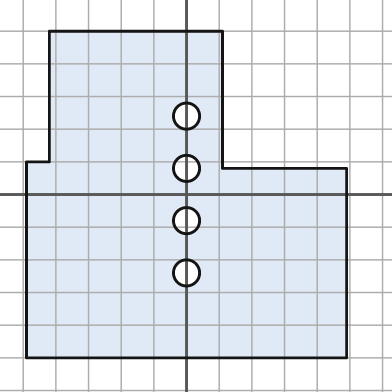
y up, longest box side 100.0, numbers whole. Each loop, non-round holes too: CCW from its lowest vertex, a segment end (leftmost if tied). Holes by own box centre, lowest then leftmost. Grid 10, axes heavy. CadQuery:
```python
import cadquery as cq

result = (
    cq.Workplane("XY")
    .moveTo(-49.0, -50.0)
    .lineTo(49.0, -50.0)
    .lineTo(49.0, 8.0)
    .lineTo(11.0, 8.0)
    .lineTo(11.0, 50.0)
    .lineTo(-42.0, 50.0)
    .lineTo(-42.0, 10.0)
    .lineTo(-49.0, 10.0)
    .close()
    .moveTo(0.0, -24.0)
    .circle(4.0)
    .moveTo(0.0, -8.0)
    .circle(4.0)
    .moveTo(0.0, 8.0)
    .circle(4.0)
    .moveTo(0.0, 24.0)
    .circle(4.0)
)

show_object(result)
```